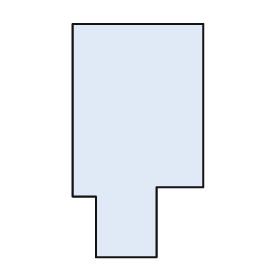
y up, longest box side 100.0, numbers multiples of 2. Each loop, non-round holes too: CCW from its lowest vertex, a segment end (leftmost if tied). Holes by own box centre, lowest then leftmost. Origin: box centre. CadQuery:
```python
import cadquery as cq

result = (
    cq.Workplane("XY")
    .moveTo(-18.0, -50.0)
    .lineTo(8.0, -50.0)
    .lineTo(8.0, -20.0)
    .lineTo(28.0, -20.0)
    .lineTo(28.0, 50.0)
    .lineTo(-28.0, 50.0)
    .lineTo(-28.0, -24.0)
    .lineTo(-18.0, -24.0)
    .close()
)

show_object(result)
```